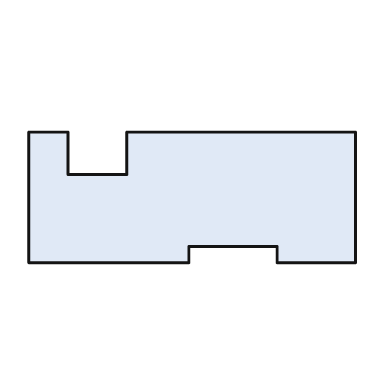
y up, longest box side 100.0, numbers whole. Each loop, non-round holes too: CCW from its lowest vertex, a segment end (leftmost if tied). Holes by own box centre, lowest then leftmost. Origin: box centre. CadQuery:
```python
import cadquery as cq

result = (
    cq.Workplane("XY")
    .moveTo(-50.0, -20.0)
    .lineTo(-1.0, -20.0)
    .lineTo(-1.0, -15.0)
    .lineTo(26.0, -15.0)
    .lineTo(26.0, -20.0)
    .lineTo(50.0, -20.0)
    .lineTo(50.0, 20.0)
    .lineTo(-20.0, 20.0)
    .lineTo(-20.0, 7.0)
    .lineTo(-38.0, 7.0)
    .lineTo(-38.0, 20.0)
    .lineTo(-50.0, 20.0)
    .close()
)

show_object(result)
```